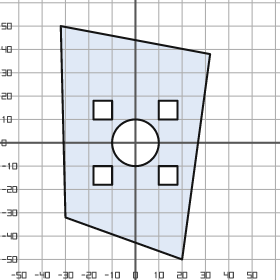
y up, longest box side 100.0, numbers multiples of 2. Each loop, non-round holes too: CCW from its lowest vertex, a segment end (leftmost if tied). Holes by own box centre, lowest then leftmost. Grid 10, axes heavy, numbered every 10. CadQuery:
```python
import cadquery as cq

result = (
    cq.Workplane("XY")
    .moveTo(20.0, -50.0)
    .lineTo(32.0, 38.0)
    .lineTo(-32.0, 50.0)
    .lineTo(-30.0, -32.0)
    .close()
    .moveTo(-18.0, -18.0)
    .lineTo(-10.0, -18.0)
    .lineTo(-10.0, -10.0)
    .lineTo(-18.0, -10.0)
    .close()
    .moveTo(10.0, -18.0)
    .lineTo(18.0, -18.0)
    .lineTo(18.0, -10.0)
    .lineTo(10.0, -10.0)
    .close()
    .moveTo(0.0, 0.0)
    .circle(10.0)
    .moveTo(-18.0, 10.0)
    .lineTo(-10.0, 10.0)
    .lineTo(-10.0, 18.0)
    .lineTo(-18.0, 18.0)
    .close()
    .moveTo(10.0, 10.0)
    .lineTo(18.0, 10.0)
    .lineTo(18.0, 18.0)
    .lineTo(10.0, 18.0)
    .close()
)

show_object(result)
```